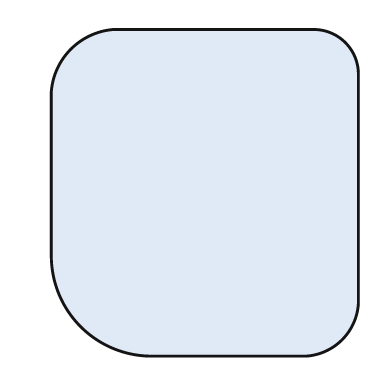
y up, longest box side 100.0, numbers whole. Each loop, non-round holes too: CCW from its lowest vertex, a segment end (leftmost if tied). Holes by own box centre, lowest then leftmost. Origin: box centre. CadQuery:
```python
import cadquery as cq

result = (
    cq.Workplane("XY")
    .moveTo(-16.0, -50.0)
    .lineTo(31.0, -50.0)
    .threePointArc((42.0, -45.0), (47.0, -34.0))
    .lineTo(47.0, 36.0)
    .threePointArc((43.0, 46.0), (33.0, 50.0))
    .lineTo(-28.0, 50.0)
    .threePointArc((-41.0, 44.0), (-47.0, 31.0))
    .lineTo(-47.0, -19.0)
    .threePointArc((-38.0, -41.0), (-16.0, -50.0))
    .close()
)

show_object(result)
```